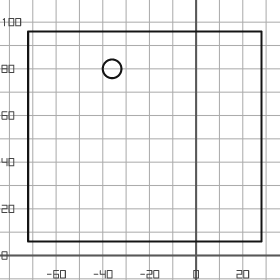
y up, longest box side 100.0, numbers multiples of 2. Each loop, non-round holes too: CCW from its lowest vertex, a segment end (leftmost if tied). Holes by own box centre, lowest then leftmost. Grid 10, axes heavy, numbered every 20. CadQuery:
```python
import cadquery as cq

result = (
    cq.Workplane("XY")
    .moveTo(-72.0, 6.0)
    .lineTo(28.0, 6.0)
    .lineTo(28.0, 96.0)
    .lineTo(-72.0, 96.0)
    .close()
    .moveTo(-36.0, 80.0)
    .circle(4.0)
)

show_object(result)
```